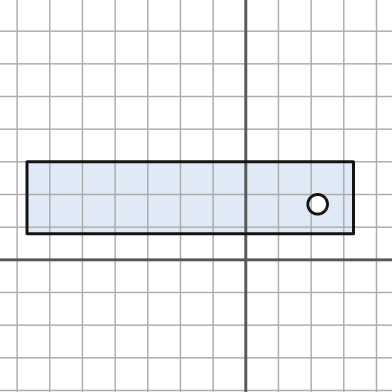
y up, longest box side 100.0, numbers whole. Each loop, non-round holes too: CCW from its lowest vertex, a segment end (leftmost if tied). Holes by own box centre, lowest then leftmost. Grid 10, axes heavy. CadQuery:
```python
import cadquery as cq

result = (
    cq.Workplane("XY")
    .moveTo(-67.0, 8.0)
    .lineTo(33.0, 8.0)
    .lineTo(33.0, 30.0)
    .lineTo(-67.0, 30.0)
    .close()
    .moveTo(22.0, 17.0)
    .circle(3.0)
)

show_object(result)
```